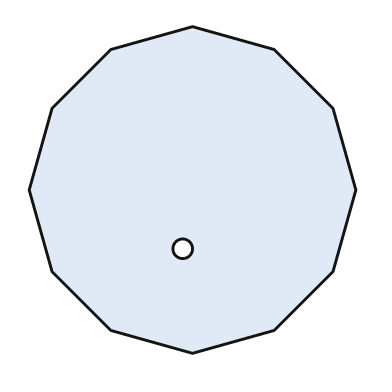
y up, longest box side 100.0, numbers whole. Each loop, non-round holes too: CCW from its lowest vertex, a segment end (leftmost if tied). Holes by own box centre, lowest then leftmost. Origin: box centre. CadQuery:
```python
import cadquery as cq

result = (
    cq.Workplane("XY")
    .moveTo(0.0, -50.0)
    .lineTo(25.0, -43.0)
    .lineTo(43.0, -25.0)
    .lineTo(50.0, 0.0)
    .lineTo(43.0, 25.0)
    .lineTo(25.0, 43.0)
    .lineTo(0.0, 50.0)
    .lineTo(-25.0, 43.0)
    .lineTo(-43.0, 25.0)
    .lineTo(-50.0, 0.0)
    .lineTo(-43.0, -25.0)
    .lineTo(-25.0, -43.0)
    .close()
    .moveTo(-3.0, -18.0)
    .circle(3.0)
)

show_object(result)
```